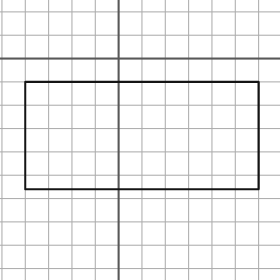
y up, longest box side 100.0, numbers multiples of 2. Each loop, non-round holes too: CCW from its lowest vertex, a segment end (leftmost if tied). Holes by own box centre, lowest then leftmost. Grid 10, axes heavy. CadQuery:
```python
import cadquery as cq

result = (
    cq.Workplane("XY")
    .moveTo(-40.0, -56.0)
    .lineTo(60.0, -56.0)
    .lineTo(60.0, -10.0)
    .lineTo(-40.0, -10.0)
    .close()
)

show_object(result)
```